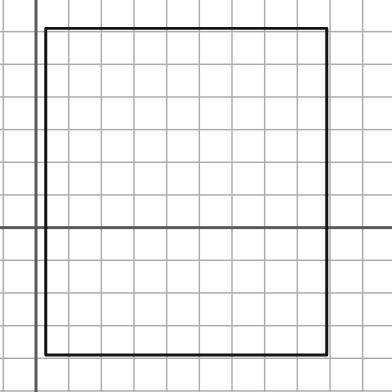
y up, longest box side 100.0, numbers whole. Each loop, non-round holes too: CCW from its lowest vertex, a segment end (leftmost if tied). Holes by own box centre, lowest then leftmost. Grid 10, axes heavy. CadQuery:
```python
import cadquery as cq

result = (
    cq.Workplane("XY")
    .moveTo(3.0, -39.0)
    .lineTo(89.0, -39.0)
    .lineTo(89.0, 61.0)
    .lineTo(3.0, 61.0)
    .close()
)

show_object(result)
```